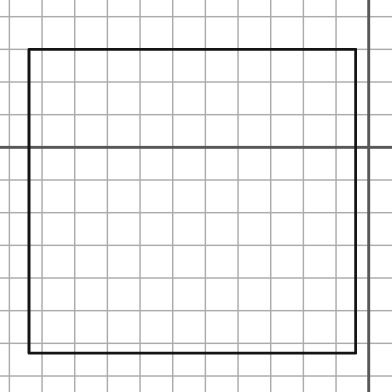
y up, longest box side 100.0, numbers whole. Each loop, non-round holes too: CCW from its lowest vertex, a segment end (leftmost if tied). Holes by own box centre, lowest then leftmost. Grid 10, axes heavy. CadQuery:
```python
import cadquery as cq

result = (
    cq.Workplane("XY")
    .moveTo(-104.0, -63.0)
    .lineTo(-4.0, -63.0)
    .lineTo(-4.0, 30.0)
    .lineTo(-104.0, 30.0)
    .close()
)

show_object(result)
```